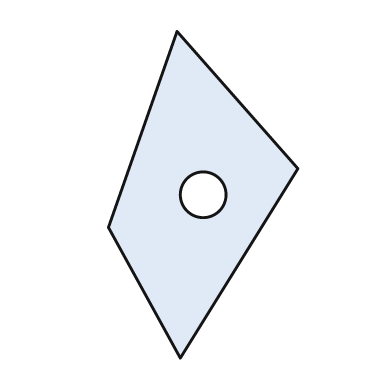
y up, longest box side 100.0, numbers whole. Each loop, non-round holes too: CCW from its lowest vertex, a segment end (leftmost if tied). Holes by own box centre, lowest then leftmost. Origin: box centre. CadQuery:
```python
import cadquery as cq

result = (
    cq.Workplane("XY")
    .moveTo(-7.0, -50.0)
    .lineTo(29.0, 8.0)
    .lineTo(-8.0, 50.0)
    .lineTo(-29.0, -10.0)
    .close()
    .moveTo(0.0, 0.0)
    .circle(7.0)
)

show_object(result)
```